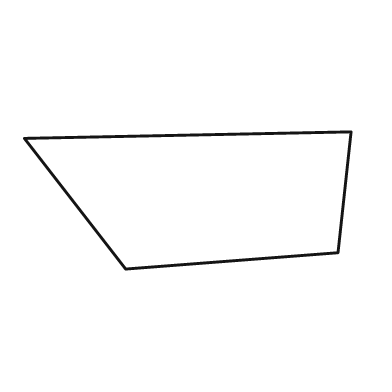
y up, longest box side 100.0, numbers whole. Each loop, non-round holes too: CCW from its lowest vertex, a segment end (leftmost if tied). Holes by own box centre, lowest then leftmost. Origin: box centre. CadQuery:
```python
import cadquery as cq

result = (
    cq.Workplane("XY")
    .moveTo(-19.0, -21.0)
    .lineTo(46.0, -16.0)
    .lineTo(50.0, 21.0)
    .lineTo(-50.0, 19.0)
    .close()
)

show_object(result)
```